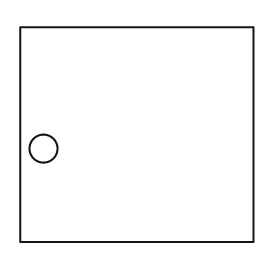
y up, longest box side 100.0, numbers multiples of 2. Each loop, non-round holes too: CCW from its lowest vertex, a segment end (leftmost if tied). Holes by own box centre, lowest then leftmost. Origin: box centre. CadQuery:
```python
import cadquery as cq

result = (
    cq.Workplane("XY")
    .moveTo(-50.0, -46.0)
    .lineTo(50.0, -46.0)
    .lineTo(50.0, 46.0)
    .lineTo(-50.0, 46.0)
    .close()
    .moveTo(-40.0, -6.0)
    .circle(6.0)
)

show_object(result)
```